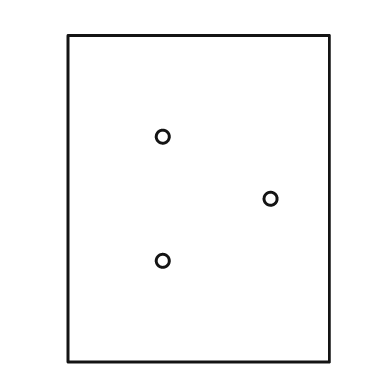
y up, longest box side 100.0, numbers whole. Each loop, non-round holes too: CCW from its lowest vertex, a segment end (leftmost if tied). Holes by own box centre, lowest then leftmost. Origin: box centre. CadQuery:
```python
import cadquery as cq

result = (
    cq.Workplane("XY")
    .moveTo(-40.0, -50.0)
    .lineTo(40.0, -50.0)
    .lineTo(40.0, 50.0)
    .lineTo(-40.0, 50.0)
    .close()
    .moveTo(-11.0, -19.0)
    .circle(2.0)
    .moveTo(22.0, 0.0)
    .circle(2.0)
    .moveTo(-11.0, 19.0)
    .circle(2.0)
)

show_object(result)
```